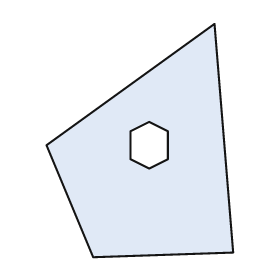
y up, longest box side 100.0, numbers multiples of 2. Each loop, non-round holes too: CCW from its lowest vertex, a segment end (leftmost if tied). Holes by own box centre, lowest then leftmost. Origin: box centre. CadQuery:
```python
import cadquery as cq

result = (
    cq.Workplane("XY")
    .moveTo(-20.0, -50.0)
    .lineTo(40.0, -48.0)
    .lineTo(32.0, 50.0)
    .lineTo(-40.0, -2.0)
    .close()
    .moveTo(4.0, -12.0)
    .lineTo(12.0, -8.0)
    .lineTo(12.0, 4.0)
    .lineTo(4.0, 8.0)
    .lineTo(-4.0, 4.0)
    .lineTo(-4.0, -8.0)
    .close()
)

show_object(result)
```